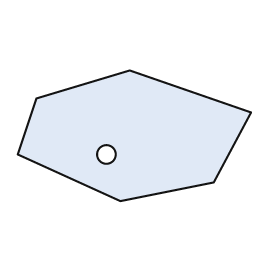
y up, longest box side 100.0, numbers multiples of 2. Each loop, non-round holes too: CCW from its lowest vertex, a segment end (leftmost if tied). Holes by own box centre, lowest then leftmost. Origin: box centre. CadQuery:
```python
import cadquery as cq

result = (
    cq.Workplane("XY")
    .moveTo(-6.0, -28.0)
    .lineTo(34.0, -20.0)
    .lineTo(50.0, 10.0)
    .lineTo(-2.0, 28.0)
    .lineTo(-42.0, 16.0)
    .lineTo(-50.0, -8.0)
    .close()
    .moveTo(-12.0, -8.0)
    .circle(4.0)
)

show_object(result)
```